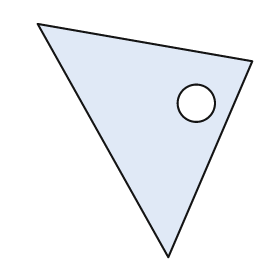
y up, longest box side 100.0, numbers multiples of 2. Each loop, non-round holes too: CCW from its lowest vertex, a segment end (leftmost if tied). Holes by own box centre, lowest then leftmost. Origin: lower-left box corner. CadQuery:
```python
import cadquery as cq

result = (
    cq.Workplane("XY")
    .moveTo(56.0, 0.0)
    .lineTo(92.0, 84.0)
    .lineTo(0.0, 100.0)
    .close()
    .moveTo(68.0, 66.0)
    .circle(8.0)
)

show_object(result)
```